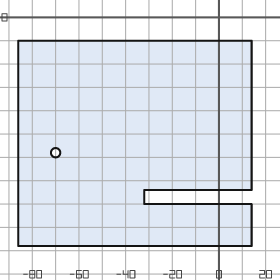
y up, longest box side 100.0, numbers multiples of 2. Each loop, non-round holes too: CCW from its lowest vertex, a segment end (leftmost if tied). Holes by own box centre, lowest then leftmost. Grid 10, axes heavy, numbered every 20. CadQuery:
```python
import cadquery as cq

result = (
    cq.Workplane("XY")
    .moveTo(-86.0, -98.0)
    .lineTo(14.0, -98.0)
    .lineTo(14.0, -80.0)
    .lineTo(-32.0, -80.0)
    .lineTo(-32.0, -74.0)
    .lineTo(14.0, -74.0)
    .lineTo(14.0, -10.0)
    .lineTo(-86.0, -10.0)
    .close()
    .moveTo(-70.0, -58.0)
    .circle(2.0)
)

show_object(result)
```